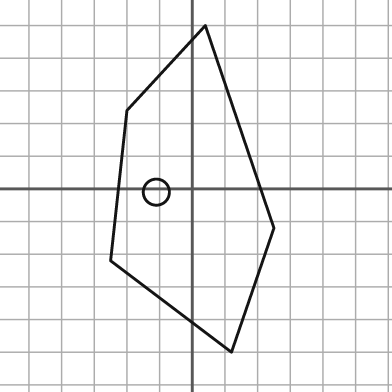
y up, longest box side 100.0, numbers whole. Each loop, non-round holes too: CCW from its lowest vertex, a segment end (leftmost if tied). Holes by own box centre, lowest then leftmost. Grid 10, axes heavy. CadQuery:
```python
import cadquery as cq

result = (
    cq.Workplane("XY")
    .moveTo(12.0, -50.0)
    .lineTo(25.0, -12.0)
    .lineTo(4.0, 50.0)
    .lineTo(-20.0, 24.0)
    .lineTo(-25.0, -22.0)
    .close()
    .moveTo(-11.0, -1.0)
    .circle(4.0)
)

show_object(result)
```